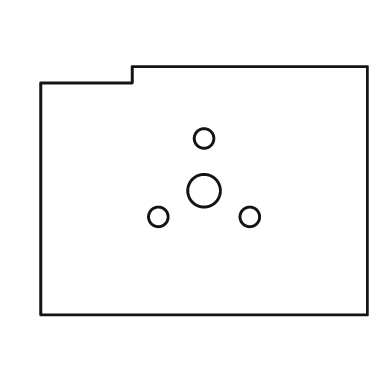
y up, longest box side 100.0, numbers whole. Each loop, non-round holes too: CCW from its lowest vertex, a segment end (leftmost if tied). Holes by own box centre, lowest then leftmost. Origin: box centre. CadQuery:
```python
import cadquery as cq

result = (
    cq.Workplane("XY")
    .moveTo(-50.0, -38.0)
    .lineTo(50.0, -38.0)
    .lineTo(50.0, 38.0)
    .lineTo(-22.0, 38.0)
    .lineTo(-22.0, 33.0)
    .lineTo(-50.0, 33.0)
    .close()
    .moveTo(-14.0, -8.0)
    .circle(3.0)
    .moveTo(14.0, -8.0)
    .circle(3.0)
    .moveTo(0.0, 0.0)
    .circle(5.0)
    .moveTo(0.0, 16.0)
    .circle(3.0)
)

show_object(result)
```